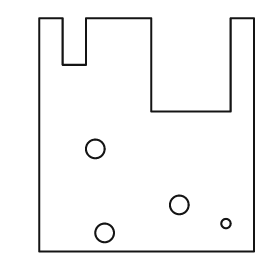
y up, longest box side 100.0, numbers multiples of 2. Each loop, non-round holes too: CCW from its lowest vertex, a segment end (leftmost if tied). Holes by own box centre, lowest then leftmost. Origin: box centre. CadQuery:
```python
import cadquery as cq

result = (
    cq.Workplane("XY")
    .moveTo(-46.0, -50.0)
    .lineTo(46.0, -50.0)
    .lineTo(46.0, 50.0)
    .lineTo(36.0, 50.0)
    .lineTo(36.0, 10.0)
    .lineTo(2.0, 10.0)
    .lineTo(2.0, 50.0)
    .lineTo(-26.0, 50.0)
    .lineTo(-26.0, 30.0)
    .lineTo(-36.0, 30.0)
    .lineTo(-36.0, 50.0)
    .lineTo(-46.0, 50.0)
    .close()
    .moveTo(-18.0, -42.0)
    .circle(4.0)
    .moveTo(34.0, -38.0)
    .circle(2.0)
    .moveTo(14.0, -30.0)
    .circle(4.0)
    .moveTo(-22.0, -6.0)
    .circle(4.0)
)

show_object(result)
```